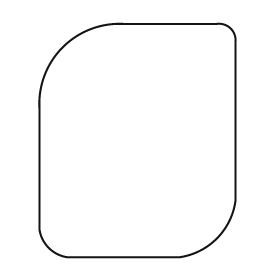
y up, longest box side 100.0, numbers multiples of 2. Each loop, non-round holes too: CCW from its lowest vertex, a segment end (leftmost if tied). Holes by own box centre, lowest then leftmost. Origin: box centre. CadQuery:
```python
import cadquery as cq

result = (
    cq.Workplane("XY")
    .moveTo(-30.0, -50.0)
    .lineTo(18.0, -50.0)
    .threePointArc((34.0, -42.0), (42.0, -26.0))
    .lineTo(42.0, 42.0)
    .threePointArc((40.0, 48.0), (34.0, 50.0))
    .lineTo(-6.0, 50.0)
    .threePointArc((-32.0, 40.0), (-42.0, 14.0))
    .lineTo(-42.0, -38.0)
    .threePointArc((-38.0, -46.0), (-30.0, -50.0))
    .close()
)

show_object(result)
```